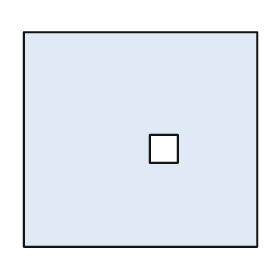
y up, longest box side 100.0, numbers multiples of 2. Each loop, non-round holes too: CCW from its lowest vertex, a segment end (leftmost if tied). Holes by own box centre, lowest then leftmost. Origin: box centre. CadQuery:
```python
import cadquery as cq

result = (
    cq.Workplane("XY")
    .moveTo(-50.0, -46.0)
    .lineTo(50.0, -46.0)
    .lineTo(50.0, 46.0)
    .lineTo(-50.0, 46.0)
    .close()
    .moveTo(4.0, -10.0)
    .lineTo(16.0, -10.0)
    .lineTo(16.0, 2.0)
    .lineTo(4.0, 2.0)
    .close()
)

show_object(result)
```